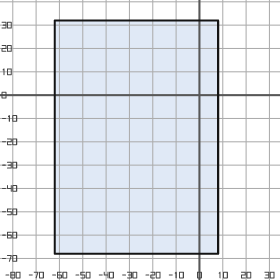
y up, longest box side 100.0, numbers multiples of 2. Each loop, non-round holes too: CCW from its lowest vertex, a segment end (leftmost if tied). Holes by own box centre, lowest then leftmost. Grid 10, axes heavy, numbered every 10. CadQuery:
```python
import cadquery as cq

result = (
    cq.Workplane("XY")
    .moveTo(-62.0, -68.0)
    .lineTo(8.0, -68.0)
    .lineTo(8.0, 32.0)
    .lineTo(-62.0, 32.0)
    .close()
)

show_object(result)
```